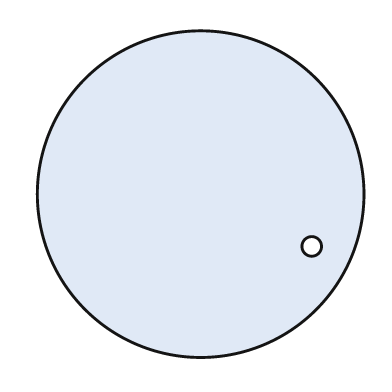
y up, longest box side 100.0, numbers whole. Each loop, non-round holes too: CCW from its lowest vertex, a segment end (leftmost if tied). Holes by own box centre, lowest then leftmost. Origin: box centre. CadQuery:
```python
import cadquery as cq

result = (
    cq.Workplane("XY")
    .moveTo(0.0, 0.0)
    .circle(50.0)
    .moveTo(34.0, -16.0)
    .circle(3.0)
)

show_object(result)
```